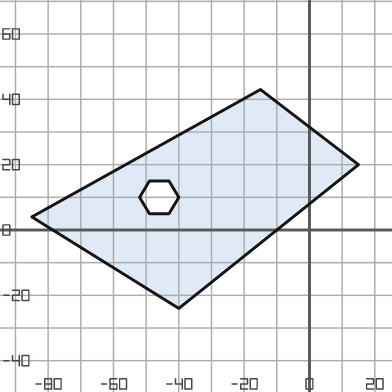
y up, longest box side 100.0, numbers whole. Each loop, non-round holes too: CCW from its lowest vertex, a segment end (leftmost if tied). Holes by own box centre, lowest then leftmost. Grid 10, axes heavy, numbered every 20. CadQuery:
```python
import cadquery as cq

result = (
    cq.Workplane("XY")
    .moveTo(-40.0, -24.0)
    .lineTo(15.0, 20.0)
    .lineTo(-15.0, 43.0)
    .lineTo(-85.0, 4.0)
    .close()
    .moveTo(-49.0, 5.0)
    .lineTo(-43.0, 5.0)
    .lineTo(-40.0, 10.0)
    .lineTo(-43.0, 15.0)
    .lineTo(-49.0, 15.0)
    .lineTo(-52.0, 10.0)
    .close()
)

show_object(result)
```